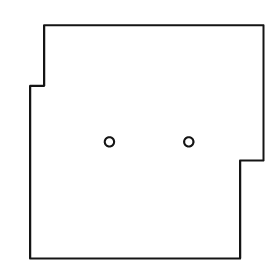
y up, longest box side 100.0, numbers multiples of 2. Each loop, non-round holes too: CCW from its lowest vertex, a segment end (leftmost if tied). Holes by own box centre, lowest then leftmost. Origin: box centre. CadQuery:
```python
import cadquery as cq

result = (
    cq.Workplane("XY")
    .moveTo(-50.0, -50.0)
    .lineTo(40.0, -50.0)
    .lineTo(40.0, -8.0)
    .lineTo(50.0, -8.0)
    .lineTo(50.0, 50.0)
    .lineTo(-44.0, 50.0)
    .lineTo(-44.0, 24.0)
    .lineTo(-50.0, 24.0)
    .close()
    .moveTo(-16.0, 0.0)
    .circle(2.0)
    .moveTo(18.0, 0.0)
    .circle(2.0)
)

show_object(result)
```